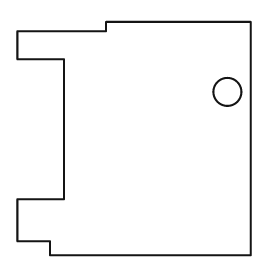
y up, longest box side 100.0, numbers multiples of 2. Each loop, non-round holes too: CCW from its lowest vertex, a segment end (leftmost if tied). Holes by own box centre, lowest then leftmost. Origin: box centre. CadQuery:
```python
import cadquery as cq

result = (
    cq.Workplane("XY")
    .moveTo(-36.0, -50.0)
    .lineTo(50.0, -50.0)
    .lineTo(50.0, 50.0)
    .lineTo(-12.0, 50.0)
    .lineTo(-12.0, 46.0)
    .lineTo(-50.0, 46.0)
    .lineTo(-50.0, 34.0)
    .lineTo(-30.0, 34.0)
    .lineTo(-30.0, -26.0)
    .lineTo(-50.0, -26.0)
    .lineTo(-50.0, -44.0)
    .lineTo(-36.0, -44.0)
    .close()
    .moveTo(40.0, 20.0)
    .circle(6.0)
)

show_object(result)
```